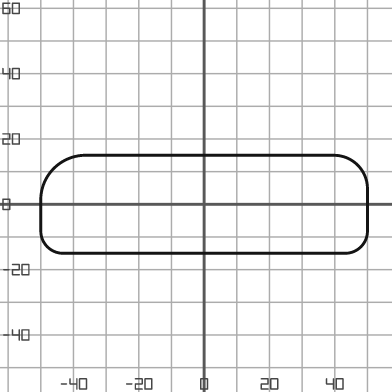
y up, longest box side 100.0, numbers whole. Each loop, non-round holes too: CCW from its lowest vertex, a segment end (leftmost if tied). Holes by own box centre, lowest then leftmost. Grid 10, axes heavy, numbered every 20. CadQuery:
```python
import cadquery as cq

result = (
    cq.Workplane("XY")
    .moveTo(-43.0, -15.0)
    .lineTo(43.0, -15.0)
    .threePointArc((48.0, -13.0), (50.0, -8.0))
    .lineTo(50.0, 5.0)
    .threePointArc((47.0, 12.0), (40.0, 15.0))
    .lineTo(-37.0, 15.0)
    .threePointArc((-46.0, 11.0), (-50.0, 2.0))
    .lineTo(-50.0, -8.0)
    .threePointArc((-48.0, -13.0), (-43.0, -15.0))
    .close()
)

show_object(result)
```